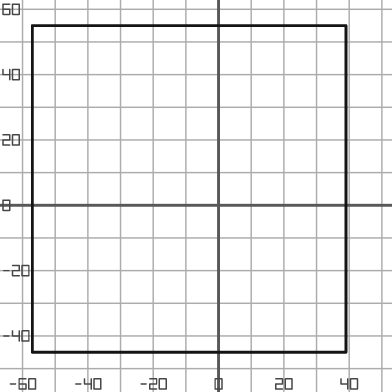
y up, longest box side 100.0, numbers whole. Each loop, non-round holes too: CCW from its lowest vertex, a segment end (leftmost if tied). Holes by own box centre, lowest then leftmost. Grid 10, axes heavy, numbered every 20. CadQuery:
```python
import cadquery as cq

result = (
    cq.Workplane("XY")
    .moveTo(-57.0, -45.0)
    .lineTo(39.0, -45.0)
    .lineTo(39.0, 55.0)
    .lineTo(-57.0, 55.0)
    .close()
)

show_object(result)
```